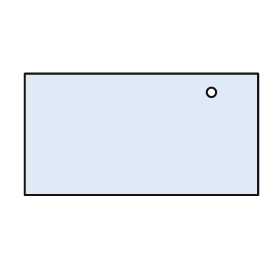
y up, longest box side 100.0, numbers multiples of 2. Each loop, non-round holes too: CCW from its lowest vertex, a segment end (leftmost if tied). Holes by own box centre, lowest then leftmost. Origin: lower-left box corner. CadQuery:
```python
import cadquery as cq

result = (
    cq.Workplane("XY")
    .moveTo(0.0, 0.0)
    .lineTo(100.0, 0.0)
    .lineTo(100.0, 52.0)
    .lineTo(0.0, 52.0)
    .close()
    .moveTo(80.0, 44.0)
    .circle(2.0)
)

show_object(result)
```